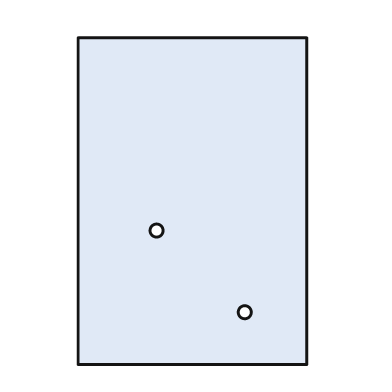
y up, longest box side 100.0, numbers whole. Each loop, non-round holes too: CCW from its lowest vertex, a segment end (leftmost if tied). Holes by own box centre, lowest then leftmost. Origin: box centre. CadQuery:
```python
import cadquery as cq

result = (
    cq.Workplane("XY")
    .moveTo(-35.0, -50.0)
    .lineTo(35.0, -50.0)
    .lineTo(35.0, 50.0)
    .lineTo(-35.0, 50.0)
    .close()
    .moveTo(16.0, -34.0)
    .circle(2.0)
    .moveTo(-11.0, -9.0)
    .circle(2.0)
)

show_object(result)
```